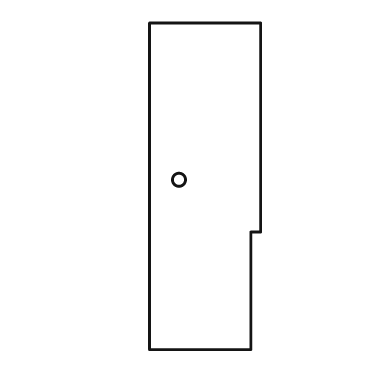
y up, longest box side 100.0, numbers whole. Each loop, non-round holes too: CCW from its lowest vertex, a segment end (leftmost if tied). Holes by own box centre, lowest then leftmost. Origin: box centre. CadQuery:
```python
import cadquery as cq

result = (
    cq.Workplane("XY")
    .moveTo(-17.0, -50.0)
    .lineTo(14.0, -50.0)
    .lineTo(14.0, -14.0)
    .lineTo(17.0, -14.0)
    .lineTo(17.0, 50.0)
    .lineTo(-17.0, 50.0)
    .close()
    .moveTo(-8.0, 2.0)
    .circle(2.0)
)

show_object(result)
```